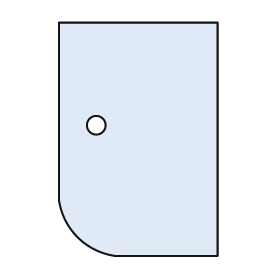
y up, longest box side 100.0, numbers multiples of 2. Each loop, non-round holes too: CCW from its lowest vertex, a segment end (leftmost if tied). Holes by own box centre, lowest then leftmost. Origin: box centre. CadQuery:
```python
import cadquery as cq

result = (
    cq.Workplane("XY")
    .moveTo(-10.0, -50.0)
    .lineTo(34.0, -50.0)
    .lineTo(34.0, 50.0)
    .lineTo(-34.0, 50.0)
    .lineTo(-34.0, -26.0)
    .threePointArc((-26.0, -42.0), (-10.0, -50.0))
    .close()
    .moveTo(-18.0, 6.0)
    .circle(4.0)
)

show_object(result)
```